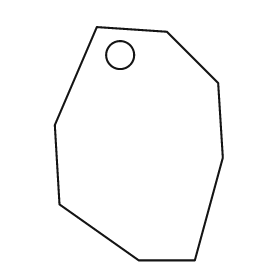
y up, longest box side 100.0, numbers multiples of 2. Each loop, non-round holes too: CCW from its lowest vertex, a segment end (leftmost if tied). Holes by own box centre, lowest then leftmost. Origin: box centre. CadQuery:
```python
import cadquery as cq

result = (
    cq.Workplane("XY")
    .moveTo(0.0, -50.0)
    .lineTo(24.0, -50.0)
    .lineTo(36.0, -6.0)
    .lineTo(34.0, 26.0)
    .lineTo(12.0, 48.0)
    .lineTo(-18.0, 50.0)
    .lineTo(-36.0, 8.0)
    .lineTo(-34.0, -26.0)
    .close()
    .moveTo(-8.0, 38.0)
    .circle(6.0)
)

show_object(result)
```